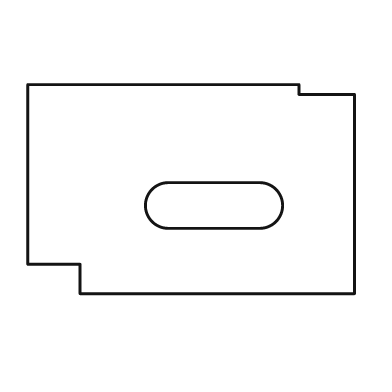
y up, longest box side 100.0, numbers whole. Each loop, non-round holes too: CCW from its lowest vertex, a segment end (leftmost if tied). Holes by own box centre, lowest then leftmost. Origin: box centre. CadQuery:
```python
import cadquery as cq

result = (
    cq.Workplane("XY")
    .moveTo(-34.0, -32.0)
    .lineTo(50.0, -32.0)
    .lineTo(50.0, 29.0)
    .lineTo(33.0, 29.0)
    .lineTo(33.0, 32.0)
    .lineTo(-50.0, 32.0)
    .lineTo(-50.0, -23.0)
    .lineTo(-34.0, -23.0)
    .close()
    .moveTo(-7.0, -12.0)
    .lineTo(21.0, -12.0)
    .threePointArc((28.0, -5.0), (21.0, 2.0))
    .lineTo(-7.0, 2.0)
    .threePointArc((-14.0, -5.0), (-7.0, -12.0))
    .close()
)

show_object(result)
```